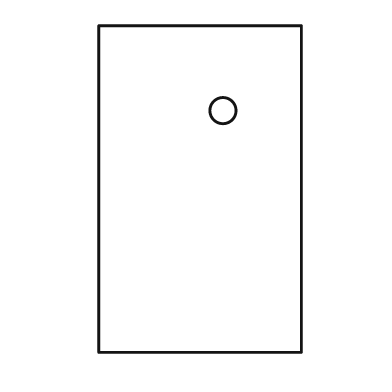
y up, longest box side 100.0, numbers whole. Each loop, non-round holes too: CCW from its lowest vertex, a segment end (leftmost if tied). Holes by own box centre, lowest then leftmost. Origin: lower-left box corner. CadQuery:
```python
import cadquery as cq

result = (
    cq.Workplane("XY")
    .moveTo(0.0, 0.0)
    .lineTo(62.0, 0.0)
    .lineTo(62.0, 100.0)
    .lineTo(0.0, 100.0)
    .close()
    .moveTo(38.0, 74.0)
    .circle(4.0)
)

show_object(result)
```